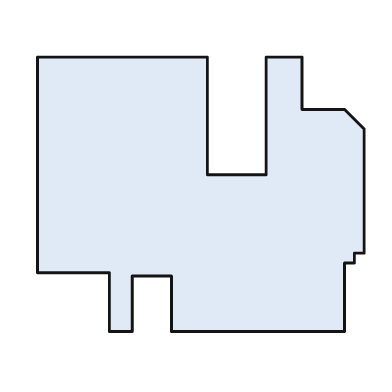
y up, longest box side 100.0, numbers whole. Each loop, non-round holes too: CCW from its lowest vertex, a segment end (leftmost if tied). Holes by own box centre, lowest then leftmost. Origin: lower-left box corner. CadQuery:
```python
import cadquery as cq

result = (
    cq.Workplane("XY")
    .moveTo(22.0, 0.0)
    .lineTo(29.0, 0.0)
    .lineTo(29.0, 17.0)
    .lineTo(41.0, 17.0)
    .lineTo(41.0, 0.0)
    .lineTo(94.0, 0.0)
    .lineTo(94.0, 21.0)
    .lineTo(97.0, 21.0)
    .lineTo(97.0, 24.0)
    .lineTo(100.0, 24.0)
    .lineTo(100.0, 62.0)
    .lineTo(94.0, 68.0)
    .lineTo(81.0, 68.0)
    .lineTo(81.0, 84.0)
    .lineTo(70.0, 84.0)
    .lineTo(70.0, 48.0)
    .lineTo(52.0, 48.0)
    .lineTo(52.0, 84.0)
    .lineTo(0.0, 84.0)
    .lineTo(0.0, 18.0)
    .lineTo(22.0, 18.0)
    .close()
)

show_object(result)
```